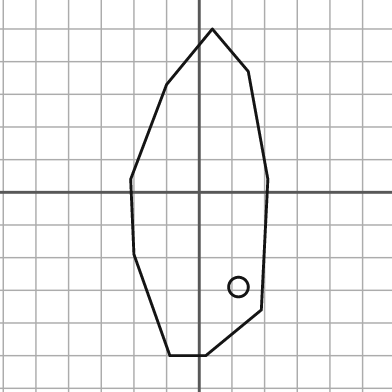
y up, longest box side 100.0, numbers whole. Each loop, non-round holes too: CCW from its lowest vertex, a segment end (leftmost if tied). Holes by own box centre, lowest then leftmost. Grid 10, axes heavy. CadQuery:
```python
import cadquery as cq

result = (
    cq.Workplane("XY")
    .moveTo(-9.0, -50.0)
    .lineTo(2.0, -50.0)
    .lineTo(19.0, -36.0)
    .lineTo(21.0, 4.0)
    .lineTo(15.0, 37.0)
    .lineTo(4.0, 50.0)
    .lineTo(-10.0, 33.0)
    .lineTo(-21.0, 4.0)
    .lineTo(-20.0, -19.0)
    .close()
    .moveTo(12.0, -29.0)
    .circle(3.0)
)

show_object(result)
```